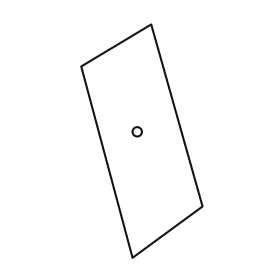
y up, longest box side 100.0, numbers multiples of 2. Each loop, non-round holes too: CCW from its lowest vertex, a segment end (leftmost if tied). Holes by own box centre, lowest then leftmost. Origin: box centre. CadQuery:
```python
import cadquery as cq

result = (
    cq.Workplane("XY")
    .moveTo(-4.0, -50.0)
    .lineTo(26.0, -28.0)
    .lineTo(4.0, 50.0)
    .lineTo(-26.0, 32.0)
    .close()
    .moveTo(-2.0, 4.0)
    .circle(2.0)
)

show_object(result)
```